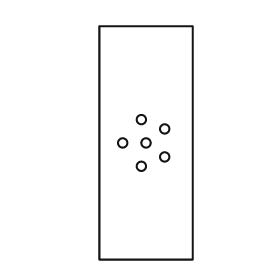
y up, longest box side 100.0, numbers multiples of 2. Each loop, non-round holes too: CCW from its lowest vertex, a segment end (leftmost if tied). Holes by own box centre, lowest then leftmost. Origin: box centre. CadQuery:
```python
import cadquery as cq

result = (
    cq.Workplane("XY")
    .moveTo(-20.0, -50.0)
    .lineTo(20.0, -50.0)
    .lineTo(20.0, 50.0)
    .lineTo(-20.0, 50.0)
    .close()
    .moveTo(-2.0, -10.0)
    .circle(2.0)
    .moveTo(8.0, -6.0)
    .circle(2.0)
    .moveTo(-10.0, 0.0)
    .circle(2.0)
    .moveTo(0.0, 0.0)
    .circle(2.0)
    .moveTo(8.0, 6.0)
    .circle(2.0)
    .moveTo(-2.0, 10.0)
    .circle(2.0)
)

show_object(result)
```